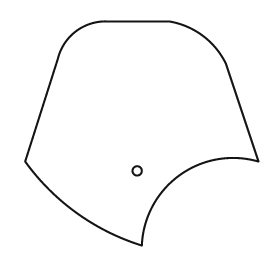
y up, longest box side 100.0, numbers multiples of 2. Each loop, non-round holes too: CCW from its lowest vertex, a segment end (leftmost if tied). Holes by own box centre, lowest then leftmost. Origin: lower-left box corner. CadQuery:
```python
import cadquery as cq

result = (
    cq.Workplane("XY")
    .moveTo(50.0, 0.0)
    .threePointArc((66.0, 30.0), (100.0, 36.0))
    .lineTo(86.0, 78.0)
    .threePointArc((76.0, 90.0), (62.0, 96.0))
    .lineTo(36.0, 96.0)
    .threePointArc((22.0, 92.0), (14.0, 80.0))
    .lineTo(0.0, 36.0)
    .threePointArc((22.0, 14.0), (50.0, 0.0))
    .close()
    .moveTo(48.0, 32.0)
    .circle(2.0)
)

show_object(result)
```